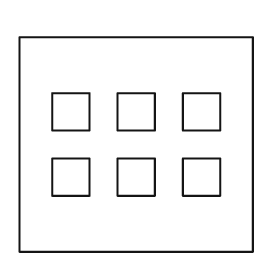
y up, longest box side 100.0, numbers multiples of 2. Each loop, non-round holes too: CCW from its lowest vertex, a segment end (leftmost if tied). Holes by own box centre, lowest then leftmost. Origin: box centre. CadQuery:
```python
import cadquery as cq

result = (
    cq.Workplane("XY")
    .moveTo(-50.0, -46.0)
    .lineTo(50.0, -46.0)
    .lineTo(50.0, 46.0)
    .lineTo(-50.0, 46.0)
    .close()
    .moveTo(-36.0, -22.0)
    .lineTo(-20.0, -22.0)
    .lineTo(-20.0, -6.0)
    .lineTo(-36.0, -6.0)
    .close()
    .moveTo(-8.0, -22.0)
    .lineTo(8.0, -22.0)
    .lineTo(8.0, -6.0)
    .lineTo(-8.0, -6.0)
    .close()
    .moveTo(20.0, -22.0)
    .lineTo(36.0, -22.0)
    .lineTo(36.0, -6.0)
    .lineTo(20.0, -6.0)
    .close()
    .moveTo(-36.0, 6.0)
    .lineTo(-20.0, 6.0)
    .lineTo(-20.0, 22.0)
    .lineTo(-36.0, 22.0)
    .close()
    .moveTo(-8.0, 6.0)
    .lineTo(8.0, 6.0)
    .lineTo(8.0, 22.0)
    .lineTo(-8.0, 22.0)
    .close()
    .moveTo(20.0, 6.0)
    .lineTo(36.0, 6.0)
    .lineTo(36.0, 22.0)
    .lineTo(20.0, 22.0)
    .close()
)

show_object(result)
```